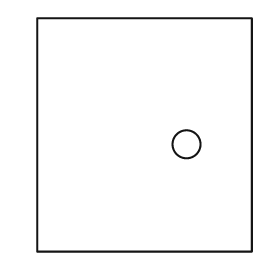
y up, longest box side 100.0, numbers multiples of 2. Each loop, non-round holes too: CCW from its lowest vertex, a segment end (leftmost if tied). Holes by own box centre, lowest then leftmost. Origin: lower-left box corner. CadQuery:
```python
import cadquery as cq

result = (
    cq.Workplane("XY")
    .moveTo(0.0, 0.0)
    .lineTo(92.0, 0.0)
    .lineTo(92.0, 100.0)
    .lineTo(0.0, 100.0)
    .close()
    .moveTo(64.0, 46.0)
    .circle(6.0)
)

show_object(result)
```